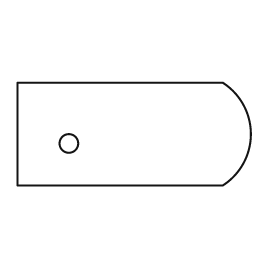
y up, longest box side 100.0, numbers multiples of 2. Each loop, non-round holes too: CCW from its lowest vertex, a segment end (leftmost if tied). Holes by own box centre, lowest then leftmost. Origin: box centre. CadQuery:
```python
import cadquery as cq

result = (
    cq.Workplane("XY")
    .moveTo(-50.0, -22.0)
    .lineTo(38.0, -22.0)
    .threePointArc((50.0, 0.0), (38.0, 22.0))
    .lineTo(-50.0, 22.0)
    .close()
    .moveTo(-28.0, -4.0)
    .circle(4.0)
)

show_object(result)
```